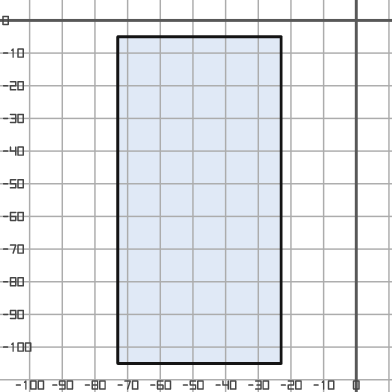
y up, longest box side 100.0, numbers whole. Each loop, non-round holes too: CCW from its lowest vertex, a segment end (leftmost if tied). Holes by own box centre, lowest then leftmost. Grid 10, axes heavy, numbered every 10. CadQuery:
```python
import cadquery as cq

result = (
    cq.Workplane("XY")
    .moveTo(-73.0, -105.0)
    .lineTo(-23.0, -105.0)
    .lineTo(-23.0, -5.0)
    .lineTo(-73.0, -5.0)
    .close()
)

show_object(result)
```